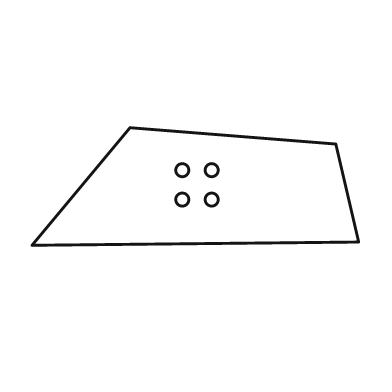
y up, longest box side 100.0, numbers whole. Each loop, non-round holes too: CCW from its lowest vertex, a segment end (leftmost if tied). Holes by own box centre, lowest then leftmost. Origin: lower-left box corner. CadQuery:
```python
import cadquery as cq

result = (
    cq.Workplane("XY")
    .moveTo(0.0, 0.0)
    .lineTo(100.0, 1.0)
    .lineTo(93.0, 31.0)
    .lineTo(30.0, 36.0)
    .close()
    .moveTo(46.0, 14.0)
    .circle(2.0)
    .moveTo(55.0, 14.0)
    .circle(2.0)
    .moveTo(46.0, 23.0)
    .circle(2.0)
    .moveTo(55.0, 23.0)
    .circle(2.0)
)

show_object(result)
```